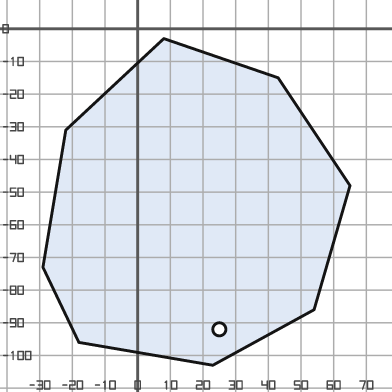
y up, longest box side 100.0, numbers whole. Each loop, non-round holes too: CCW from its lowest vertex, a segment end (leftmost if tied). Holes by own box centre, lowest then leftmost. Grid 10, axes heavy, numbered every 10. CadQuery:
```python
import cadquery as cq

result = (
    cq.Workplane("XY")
    .moveTo(23.0, -103.0)
    .lineTo(54.0, -86.0)
    .lineTo(65.0, -48.0)
    .lineTo(43.0, -15.0)
    .lineTo(8.0, -3.0)
    .lineTo(-22.0, -31.0)
    .lineTo(-29.0, -73.0)
    .lineTo(-18.0, -96.0)
    .close()
    .moveTo(25.0, -92.0)
    .circle(2.0)
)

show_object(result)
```